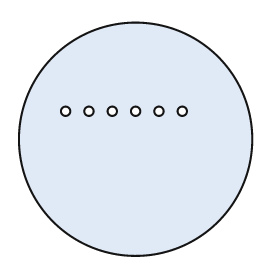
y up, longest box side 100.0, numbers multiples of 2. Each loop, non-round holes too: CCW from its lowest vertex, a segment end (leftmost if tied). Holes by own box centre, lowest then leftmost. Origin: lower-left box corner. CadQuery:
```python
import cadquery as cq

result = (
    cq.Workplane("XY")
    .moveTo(50.0, 50.0)
    .circle(50.0)
    .moveTo(20.0, 62.0)
    .circle(2.0)
    .moveTo(30.0, 62.0)
    .circle(2.0)
    .moveTo(40.0, 62.0)
    .circle(2.0)
    .moveTo(50.0, 62.0)
    .circle(2.0)
    .moveTo(60.0, 62.0)
    .circle(2.0)
    .moveTo(70.0, 62.0)
    .circle(2.0)
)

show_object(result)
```